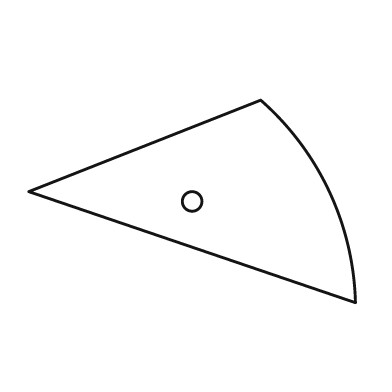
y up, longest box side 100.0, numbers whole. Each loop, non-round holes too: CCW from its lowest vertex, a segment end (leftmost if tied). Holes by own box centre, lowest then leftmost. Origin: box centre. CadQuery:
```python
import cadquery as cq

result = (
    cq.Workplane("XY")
    .moveTo(50.0, -31.0)
    .threePointArc((42.0, 3.0), (21.0, 31.0))
    .lineTo(-50.0, 3.0)
    .close()
    .moveTo(0.0, 0.0)
    .circle(3.0)
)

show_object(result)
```